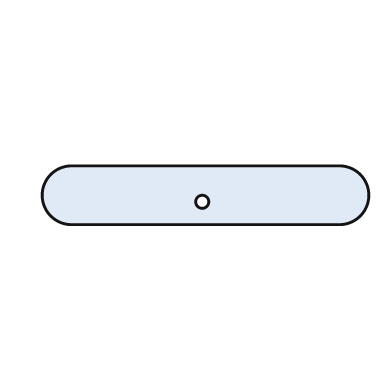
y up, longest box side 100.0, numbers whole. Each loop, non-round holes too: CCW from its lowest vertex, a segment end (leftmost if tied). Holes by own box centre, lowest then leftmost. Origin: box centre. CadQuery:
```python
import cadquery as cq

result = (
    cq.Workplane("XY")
    .moveTo(-41.0, -9.0)
    .lineTo(41.0, -9.0)
    .threePointArc((50.0, 0.0), (41.0, 9.0))
    .lineTo(-41.0, 9.0)
    .threePointArc((-50.0, 0.0), (-41.0, -9.0))
    .close()
    .moveTo(-1.0, -2.0)
    .circle(2.0)
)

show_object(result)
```